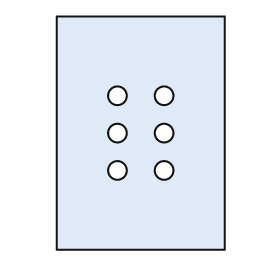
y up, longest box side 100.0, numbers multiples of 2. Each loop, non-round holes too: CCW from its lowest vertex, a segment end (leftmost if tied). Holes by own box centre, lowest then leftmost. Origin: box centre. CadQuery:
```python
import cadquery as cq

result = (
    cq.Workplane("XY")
    .moveTo(-36.0, -50.0)
    .lineTo(36.0, -50.0)
    .lineTo(36.0, 50.0)
    .lineTo(-36.0, 50.0)
    .close()
    .moveTo(-10.0, -16.0)
    .circle(4.0)
    .moveTo(10.0, -16.0)
    .circle(4.0)
    .moveTo(-10.0, 0.0)
    .circle(4.0)
    .moveTo(10.0, 0.0)
    .circle(4.0)
    .moveTo(-10.0, 16.0)
    .circle(4.0)
    .moveTo(10.0, 16.0)
    .circle(4.0)
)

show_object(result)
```